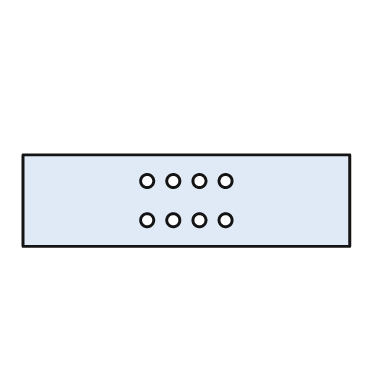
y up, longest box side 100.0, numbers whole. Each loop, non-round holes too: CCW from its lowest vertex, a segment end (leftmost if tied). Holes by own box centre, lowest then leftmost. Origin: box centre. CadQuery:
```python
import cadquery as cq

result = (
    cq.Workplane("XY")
    .moveTo(-50.0, -14.0)
    .lineTo(50.0, -14.0)
    .lineTo(50.0, 14.0)
    .lineTo(-50.0, 14.0)
    .close()
    .moveTo(-12.0, -6.0)
    .circle(2.0)
    .moveTo(-4.0, -6.0)
    .circle(2.0)
    .moveTo(4.0, -6.0)
    .circle(2.0)
    .moveTo(12.0, -6.0)
    .circle(2.0)
    .moveTo(-12.0, 6.0)
    .circle(2.0)
    .moveTo(-4.0, 6.0)
    .circle(2.0)
    .moveTo(4.0, 6.0)
    .circle(2.0)
    .moveTo(12.0, 6.0)
    .circle(2.0)
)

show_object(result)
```